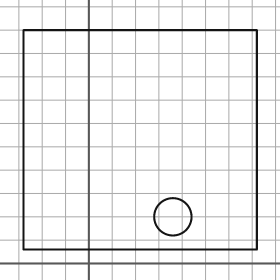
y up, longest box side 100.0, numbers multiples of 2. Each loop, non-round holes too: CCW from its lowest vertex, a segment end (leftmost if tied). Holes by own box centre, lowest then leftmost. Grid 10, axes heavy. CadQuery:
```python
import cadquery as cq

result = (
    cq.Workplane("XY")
    .moveTo(-28.0, 6.0)
    .lineTo(72.0, 6.0)
    .lineTo(72.0, 100.0)
    .lineTo(-28.0, 100.0)
    .close()
    .moveTo(36.0, 20.0)
    .circle(8.0)
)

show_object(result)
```